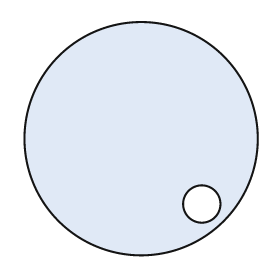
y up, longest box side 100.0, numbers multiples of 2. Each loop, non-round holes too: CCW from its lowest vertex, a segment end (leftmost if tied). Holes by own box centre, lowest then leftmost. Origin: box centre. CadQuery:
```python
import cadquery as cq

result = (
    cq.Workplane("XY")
    .moveTo(0.0, 0.0)
    .circle(50.0)
    .moveTo(26.0, -28.0)
    .circle(8.0)
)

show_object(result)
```